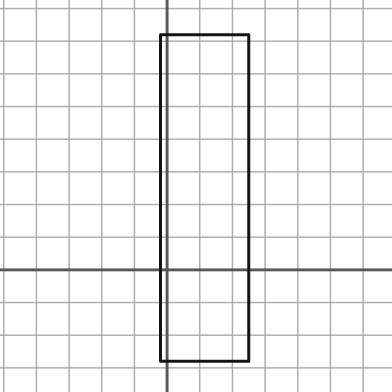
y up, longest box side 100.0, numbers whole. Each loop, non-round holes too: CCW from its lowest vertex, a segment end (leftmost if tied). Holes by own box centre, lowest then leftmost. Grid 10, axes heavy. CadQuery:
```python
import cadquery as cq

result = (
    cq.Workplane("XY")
    .moveTo(-2.0, -28.0)
    .lineTo(25.0, -28.0)
    .lineTo(25.0, 72.0)
    .lineTo(-2.0, 72.0)
    .close()
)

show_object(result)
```